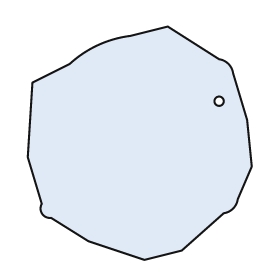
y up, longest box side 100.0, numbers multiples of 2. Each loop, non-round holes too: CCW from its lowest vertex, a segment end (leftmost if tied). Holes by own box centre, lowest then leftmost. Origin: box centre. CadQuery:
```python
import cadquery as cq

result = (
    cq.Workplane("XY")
    .moveTo(2.0, -50.0)
    .lineTo(18.0, -46.0)
    .lineTo(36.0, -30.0)
    .threePointArc((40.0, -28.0), (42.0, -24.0))
    .lineTo(48.0, -10.0)
    .lineTo(46.0, 10.0)
    .lineTo(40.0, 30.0)
    .threePointArc((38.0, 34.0), (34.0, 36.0))
    .lineTo(12.0, 50.0)
    .lineTo(-4.0, 46.0)
    .threePointArc((-18.0, 42.0), (-30.0, 34.0))
    .lineTo(-46.0, 26.0)
    .lineTo(-48.0, -6.0)
    .lineTo(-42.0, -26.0)
    .threePointArc((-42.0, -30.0), (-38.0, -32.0))
    .lineTo(-22.0, -42.0)
    .close()
    .moveTo(34.0, 18.0)
    .circle(2.0)
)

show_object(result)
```